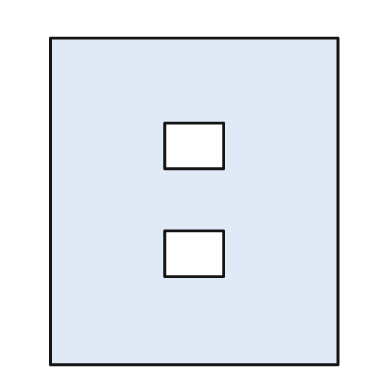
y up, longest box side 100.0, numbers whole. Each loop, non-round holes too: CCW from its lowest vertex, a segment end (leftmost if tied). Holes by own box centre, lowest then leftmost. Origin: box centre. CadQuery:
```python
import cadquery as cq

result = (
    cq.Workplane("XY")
    .moveTo(-44.0, -50.0)
    .lineTo(44.0, -50.0)
    .lineTo(44.0, 50.0)
    .lineTo(-44.0, 50.0)
    .close()
    .moveTo(-9.0, -23.0)
    .lineTo(9.0, -23.0)
    .lineTo(9.0, -9.0)
    .lineTo(-9.0, -9.0)
    .close()
    .moveTo(-9.0, 10.0)
    .lineTo(9.0, 10.0)
    .lineTo(9.0, 24.0)
    .lineTo(-9.0, 24.0)
    .close()
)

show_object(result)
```